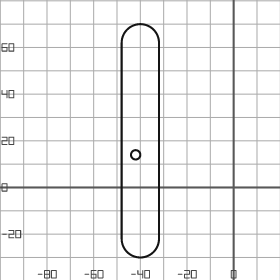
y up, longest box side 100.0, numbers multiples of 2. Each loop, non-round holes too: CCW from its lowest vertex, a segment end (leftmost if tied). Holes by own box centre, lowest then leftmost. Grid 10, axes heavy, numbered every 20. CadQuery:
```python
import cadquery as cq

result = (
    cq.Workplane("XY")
    .moveTo(-48.0, -22.0)
    .threePointArc((-40.0, -30.0), (-32.0, -22.0))
    .lineTo(-32.0, 62.0)
    .threePointArc((-40.0, 70.0), (-48.0, 62.0))
    .close()
    .moveTo(-42.0, 14.0)
    .circle(2.0)
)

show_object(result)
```